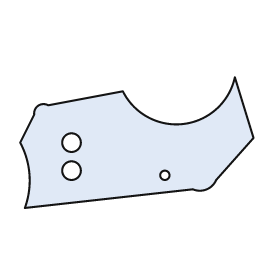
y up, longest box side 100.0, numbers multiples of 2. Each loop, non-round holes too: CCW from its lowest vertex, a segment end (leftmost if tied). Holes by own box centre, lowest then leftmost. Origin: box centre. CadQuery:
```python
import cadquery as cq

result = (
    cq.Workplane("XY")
    .moveTo(-48.0, -28.0)
    .lineTo(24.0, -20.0)
    .threePointArc((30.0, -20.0), (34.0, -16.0))
    .lineTo(50.0, 2.0)
    .lineTo(42.0, 28.0)
    .threePointArc((20.0, 8.0), (-6.0, 22.0))
    .lineTo(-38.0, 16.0)
    .threePointArc((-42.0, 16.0), (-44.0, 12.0))
    .lineTo(-50.0, 0.0)
    .threePointArc((-46.0, -14.0), (-48.0, -28.0))
    .close()
    .moveTo(12.0, -14.0)
    .circle(2.0)
    .moveTo(-28.0, -12.0)
    .circle(4.0)
    .moveTo(-28.0, 0.0)
    .circle(4.0)
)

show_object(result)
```